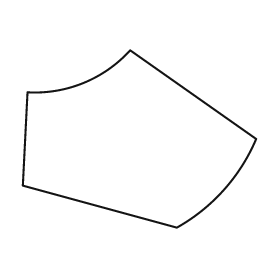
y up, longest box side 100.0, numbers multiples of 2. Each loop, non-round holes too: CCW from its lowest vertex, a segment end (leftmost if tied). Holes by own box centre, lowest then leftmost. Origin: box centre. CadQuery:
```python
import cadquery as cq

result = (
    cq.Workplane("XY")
    .moveTo(16.0, -38.0)
    .threePointArc((36.0, -22.0), (50.0, 0.0))
    .lineTo(-4.0, 38.0)
    .threePointArc((-24.0, 24.0), (-48.0, 20.0))
    .lineTo(-50.0, -20.0)
    .close()
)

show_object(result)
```